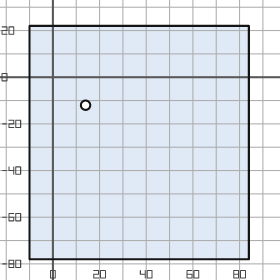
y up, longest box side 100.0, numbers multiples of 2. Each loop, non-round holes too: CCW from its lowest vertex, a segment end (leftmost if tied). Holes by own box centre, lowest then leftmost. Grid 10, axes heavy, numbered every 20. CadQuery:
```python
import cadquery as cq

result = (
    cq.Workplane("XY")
    .moveTo(-10.0, -78.0)
    .lineTo(84.0, -78.0)
    .lineTo(84.0, 22.0)
    .lineTo(-10.0, 22.0)
    .close()
    .moveTo(14.0, -12.0)
    .circle(2.0)
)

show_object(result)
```